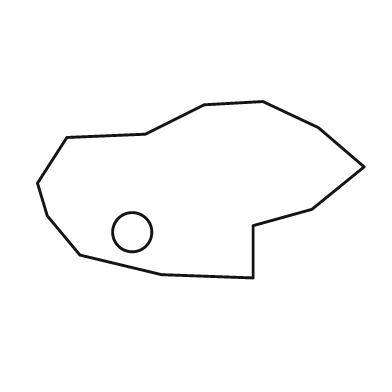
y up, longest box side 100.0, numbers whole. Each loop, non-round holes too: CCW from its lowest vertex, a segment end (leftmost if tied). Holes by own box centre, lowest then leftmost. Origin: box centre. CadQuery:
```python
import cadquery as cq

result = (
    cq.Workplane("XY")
    .moveTo(16.0, -27.0)
    .lineTo(16.0, -11.0)
    .lineTo(34.0, -6.0)
    .lineTo(50.0, 7.0)
    .lineTo(36.0, 19.0)
    .lineTo(19.0, 27.0)
    .lineTo(1.0, 26.0)
    .lineTo(-17.0, 17.0)
    .lineTo(-41.0, 16.0)
    .lineTo(-50.0, 2.0)
    .lineTo(-47.0, -8.0)
    .lineTo(-37.0, -20.0)
    .lineTo(-12.0, -26.0)
    .close()
    .moveTo(-21.0, -13.0)
    .circle(6.0)
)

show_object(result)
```